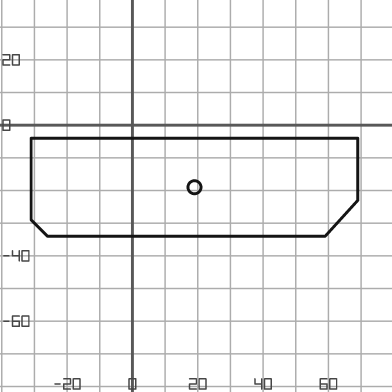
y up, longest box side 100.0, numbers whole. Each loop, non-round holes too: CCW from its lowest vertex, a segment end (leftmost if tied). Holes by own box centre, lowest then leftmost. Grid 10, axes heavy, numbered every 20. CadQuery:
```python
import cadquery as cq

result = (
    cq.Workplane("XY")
    .moveTo(-26.0, -34.0)
    .lineTo(59.0, -34.0)
    .lineTo(69.0, -23.0)
    .lineTo(69.0, -4.0)
    .lineTo(-31.0, -4.0)
    .lineTo(-31.0, -29.0)
    .close()
    .moveTo(19.0, -19.0)
    .circle(2.0)
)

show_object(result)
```